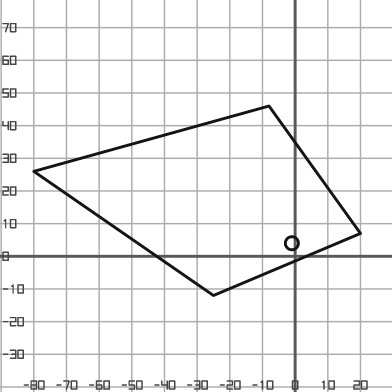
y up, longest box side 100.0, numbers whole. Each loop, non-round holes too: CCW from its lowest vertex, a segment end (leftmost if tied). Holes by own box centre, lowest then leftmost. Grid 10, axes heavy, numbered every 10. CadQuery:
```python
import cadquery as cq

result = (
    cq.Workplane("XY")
    .moveTo(-25.0, -12.0)
    .lineTo(20.0, 7.0)
    .lineTo(-8.0, 46.0)
    .lineTo(-80.0, 26.0)
    .close()
    .moveTo(-1.0, 4.0)
    .circle(2.0)
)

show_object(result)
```